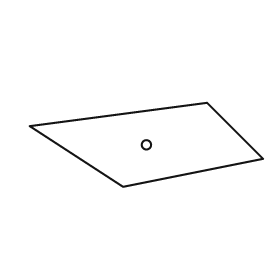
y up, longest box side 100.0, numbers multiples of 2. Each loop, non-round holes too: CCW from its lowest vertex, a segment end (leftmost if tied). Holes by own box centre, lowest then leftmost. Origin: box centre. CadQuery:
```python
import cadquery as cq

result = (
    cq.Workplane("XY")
    .moveTo(-10.0, -18.0)
    .lineTo(50.0, -6.0)
    .lineTo(26.0, 18.0)
    .lineTo(-50.0, 8.0)
    .close()
    .moveTo(0.0, 0.0)
    .circle(2.0)
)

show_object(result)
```